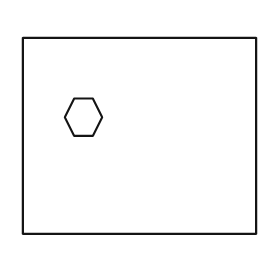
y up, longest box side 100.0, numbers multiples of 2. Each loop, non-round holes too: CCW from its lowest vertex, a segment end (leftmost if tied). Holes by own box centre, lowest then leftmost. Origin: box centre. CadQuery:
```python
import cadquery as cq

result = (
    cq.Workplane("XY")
    .moveTo(-50.0, -42.0)
    .lineTo(50.0, -42.0)
    .lineTo(50.0, 42.0)
    .lineTo(-50.0, 42.0)
    .close()
    .moveTo(-28.0, 0.0)
    .lineTo(-20.0, 0.0)
    .lineTo(-16.0, 8.0)
    .lineTo(-20.0, 16.0)
    .lineTo(-28.0, 16.0)
    .lineTo(-32.0, 8.0)
    .close()
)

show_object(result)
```